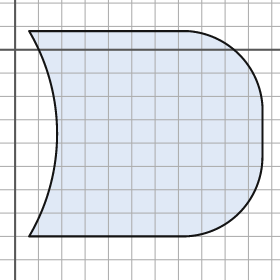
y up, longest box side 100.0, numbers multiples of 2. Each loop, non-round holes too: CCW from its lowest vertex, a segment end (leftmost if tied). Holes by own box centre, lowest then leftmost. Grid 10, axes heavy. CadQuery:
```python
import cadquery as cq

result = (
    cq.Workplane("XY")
    .moveTo(6.0, -80.0)
    .lineTo(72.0, -80.0)
    .threePointArc((96.0, -70.0), (106.0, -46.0))
    .lineTo(106.0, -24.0)
    .threePointArc((96.0, -2.0), (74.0, 8.0))
    .lineTo(6.0, 8.0)
    .threePointArc((18.0, -36.0), (6.0, -80.0))
    .close()
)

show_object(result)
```